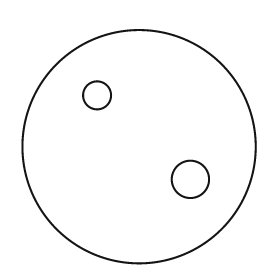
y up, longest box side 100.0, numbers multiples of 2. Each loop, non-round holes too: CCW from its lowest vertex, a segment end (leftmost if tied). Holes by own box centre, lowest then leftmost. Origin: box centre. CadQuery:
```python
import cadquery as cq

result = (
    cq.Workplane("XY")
    .moveTo(0.0, 0.0)
    .circle(50.0)
    .moveTo(22.0, -14.0)
    .circle(8.0)
    .moveTo(-18.0, 22.0)
    .circle(6.0)
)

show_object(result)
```